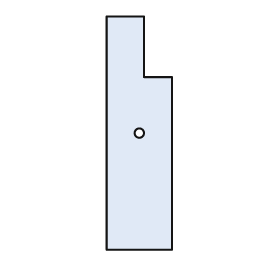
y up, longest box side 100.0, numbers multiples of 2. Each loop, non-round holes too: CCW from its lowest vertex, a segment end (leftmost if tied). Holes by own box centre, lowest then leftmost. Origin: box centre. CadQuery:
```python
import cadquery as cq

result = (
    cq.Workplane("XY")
    .moveTo(-14.0, -50.0)
    .lineTo(14.0, -50.0)
    .lineTo(14.0, 24.0)
    .lineTo(2.0, 24.0)
    .lineTo(2.0, 50.0)
    .lineTo(-14.0, 50.0)
    .close()
    .moveTo(0.0, 0.0)
    .circle(2.0)
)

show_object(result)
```